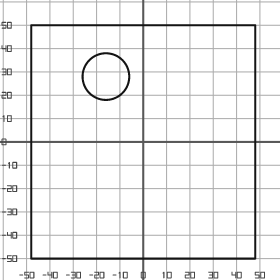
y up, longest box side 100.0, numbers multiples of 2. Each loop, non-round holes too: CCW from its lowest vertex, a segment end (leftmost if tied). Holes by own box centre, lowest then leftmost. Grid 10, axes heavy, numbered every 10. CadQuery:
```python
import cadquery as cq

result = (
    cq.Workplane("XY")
    .moveTo(-48.0, -50.0)
    .lineTo(48.0, -50.0)
    .lineTo(48.0, 50.0)
    .lineTo(-48.0, 50.0)
    .close()
    .moveTo(-16.0, 28.0)
    .circle(10.0)
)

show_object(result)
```